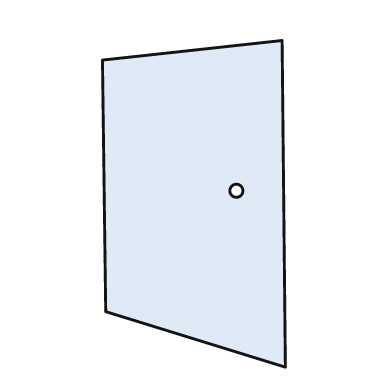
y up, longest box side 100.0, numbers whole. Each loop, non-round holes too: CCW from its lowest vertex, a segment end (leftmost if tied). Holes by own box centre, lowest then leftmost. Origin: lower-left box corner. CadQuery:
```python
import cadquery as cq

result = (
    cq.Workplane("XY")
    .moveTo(56.0, 0.0)
    .lineTo(55.0, 100.0)
    .lineTo(0.0, 94.0)
    .lineTo(1.0, 17.0)
    .close()
    .moveTo(41.0, 54.0)
    .circle(2.0)
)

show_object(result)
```